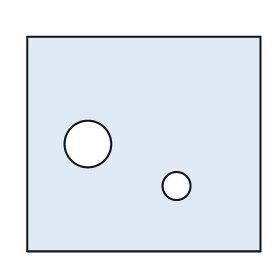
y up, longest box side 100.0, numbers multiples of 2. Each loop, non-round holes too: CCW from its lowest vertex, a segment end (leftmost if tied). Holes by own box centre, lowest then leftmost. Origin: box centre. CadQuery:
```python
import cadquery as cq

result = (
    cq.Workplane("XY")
    .moveTo(-50.0, -46.0)
    .lineTo(50.0, -46.0)
    .lineTo(50.0, 46.0)
    .lineTo(-50.0, 46.0)
    .close()
    .moveTo(14.0, -18.0)
    .circle(6.0)
    .moveTo(-24.0, 0.0)
    .circle(10.0)
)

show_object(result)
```